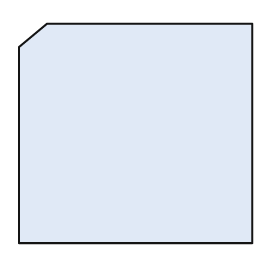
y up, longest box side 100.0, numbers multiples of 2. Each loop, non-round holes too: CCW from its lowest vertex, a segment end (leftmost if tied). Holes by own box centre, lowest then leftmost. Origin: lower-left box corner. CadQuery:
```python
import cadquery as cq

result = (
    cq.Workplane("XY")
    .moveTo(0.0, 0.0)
    .lineTo(100.0, 0.0)
    .lineTo(100.0, 94.0)
    .lineTo(12.0, 94.0)
    .lineTo(0.0, 84.0)
    .close()
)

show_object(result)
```